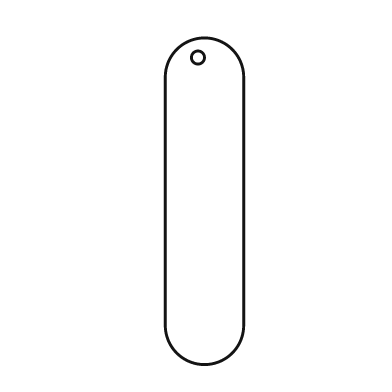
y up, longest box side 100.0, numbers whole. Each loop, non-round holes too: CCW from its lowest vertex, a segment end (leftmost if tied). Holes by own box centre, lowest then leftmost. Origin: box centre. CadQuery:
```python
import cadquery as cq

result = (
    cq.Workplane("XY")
    .moveTo(-12.0, -38.0)
    .threePointArc((0.0, -50.0), (12.0, -38.0))
    .lineTo(12.0, 38.0)
    .threePointArc((0.0, 50.0), (-12.0, 38.0))
    .close()
    .moveTo(-2.0, 44.0)
    .circle(2.0)
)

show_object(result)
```